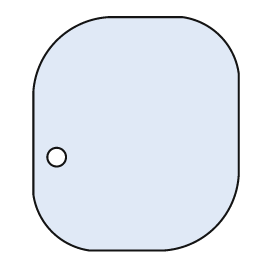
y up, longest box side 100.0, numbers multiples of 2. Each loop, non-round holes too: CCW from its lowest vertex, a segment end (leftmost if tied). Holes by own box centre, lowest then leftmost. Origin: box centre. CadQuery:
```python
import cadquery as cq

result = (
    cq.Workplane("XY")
    .moveTo(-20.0, -50.0)
    .lineTo(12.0, -50.0)
    .threePointArc((34.0, -40.0), (44.0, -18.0))
    .lineTo(44.0, 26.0)
    .threePointArc((36.0, 42.0), (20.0, 50.0))
    .lineTo(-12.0, 50.0)
    .threePointArc((-34.0, 40.0), (-44.0, 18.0))
    .lineTo(-44.0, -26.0)
    .threePointArc((-36.0, -42.0), (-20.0, -50.0))
    .close()
    .moveTo(-34.0, -10.0)
    .circle(4.0)
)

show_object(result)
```